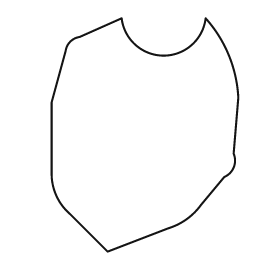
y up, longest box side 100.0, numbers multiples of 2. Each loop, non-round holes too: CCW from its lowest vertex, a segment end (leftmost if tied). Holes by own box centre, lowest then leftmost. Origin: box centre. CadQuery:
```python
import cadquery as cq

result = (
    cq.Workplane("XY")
    .moveTo(-16.0, -50.0)
    .lineTo(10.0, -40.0)
    .threePointArc((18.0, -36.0), (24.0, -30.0))
    .lineTo(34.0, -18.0)
    .threePointArc((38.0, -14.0), (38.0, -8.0))
    .lineTo(40.0, 16.0)
    .threePointArc((36.0, 34.0), (26.0, 50.0))
    .threePointArc((8.0, 34.0), (-10.0, 50.0))
    .lineTo(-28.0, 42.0)
    .threePointArc((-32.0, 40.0), (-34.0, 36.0))
    .lineTo(-40.0, 14.0)
    .lineTo(-40.0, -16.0)
    .threePointArc((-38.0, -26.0), (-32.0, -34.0))
    .close()
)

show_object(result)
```